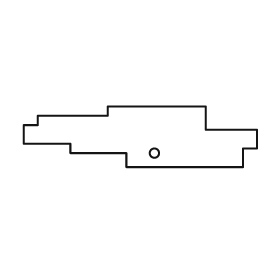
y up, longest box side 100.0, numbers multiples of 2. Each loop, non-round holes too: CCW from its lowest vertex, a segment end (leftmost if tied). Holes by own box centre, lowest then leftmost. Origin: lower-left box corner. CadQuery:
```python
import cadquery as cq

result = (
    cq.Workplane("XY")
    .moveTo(44.0, 0.0)
    .lineTo(94.0, 0.0)
    .lineTo(94.0, 8.0)
    .lineTo(100.0, 8.0)
    .lineTo(100.0, 16.0)
    .lineTo(78.0, 16.0)
    .lineTo(78.0, 26.0)
    .lineTo(36.0, 26.0)
    .lineTo(36.0, 22.0)
    .lineTo(6.0, 22.0)
    .lineTo(6.0, 18.0)
    .lineTo(0.0, 18.0)
    .lineTo(0.0, 10.0)
    .lineTo(20.0, 10.0)
    .lineTo(20.0, 6.0)
    .lineTo(44.0, 6.0)
    .close()
    .moveTo(56.0, 6.0)
    .circle(2.0)
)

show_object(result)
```